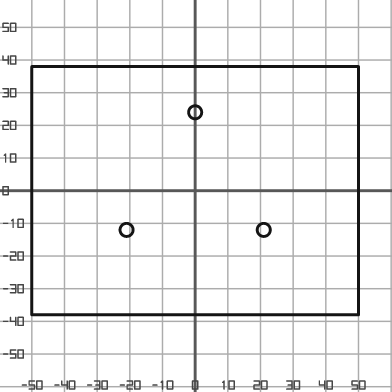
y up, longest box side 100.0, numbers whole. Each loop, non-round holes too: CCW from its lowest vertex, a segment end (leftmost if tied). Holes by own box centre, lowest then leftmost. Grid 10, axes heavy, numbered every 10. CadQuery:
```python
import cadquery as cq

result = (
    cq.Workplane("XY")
    .moveTo(-50.0, -38.0)
    .lineTo(50.0, -38.0)
    .lineTo(50.0, 38.0)
    .lineTo(-50.0, 38.0)
    .close()
    .moveTo(-21.0, -12.0)
    .circle(2.0)
    .moveTo(21.0, -12.0)
    .circle(2.0)
    .moveTo(0.0, 24.0)
    .circle(2.0)
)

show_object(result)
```